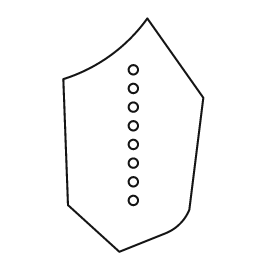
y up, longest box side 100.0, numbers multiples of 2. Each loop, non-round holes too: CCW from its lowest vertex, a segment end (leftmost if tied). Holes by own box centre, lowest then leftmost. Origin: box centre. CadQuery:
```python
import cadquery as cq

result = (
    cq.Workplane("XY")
    .moveTo(-6.0, -50.0)
    .lineTo(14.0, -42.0)
    .threePointArc((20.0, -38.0), (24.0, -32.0))
    .lineTo(30.0, 16.0)
    .lineTo(6.0, 50.0)
    .threePointArc((-10.0, 34.0), (-30.0, 24.0))
    .lineTo(-28.0, -30.0)
    .close()
    .moveTo(0.0, -28.0)
    .circle(2.0)
    .moveTo(0.0, -20.0)
    .circle(2.0)
    .moveTo(0.0, -12.0)
    .circle(2.0)
    .moveTo(0.0, -4.0)
    .circle(2.0)
    .moveTo(0.0, 4.0)
    .circle(2.0)
    .moveTo(0.0, 12.0)
    .circle(2.0)
    .moveTo(0.0, 20.0)
    .circle(2.0)
    .moveTo(0.0, 28.0)
    .circle(2.0)
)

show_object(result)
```